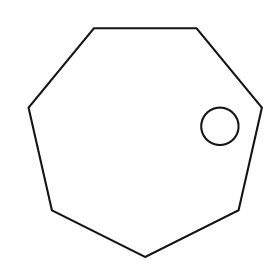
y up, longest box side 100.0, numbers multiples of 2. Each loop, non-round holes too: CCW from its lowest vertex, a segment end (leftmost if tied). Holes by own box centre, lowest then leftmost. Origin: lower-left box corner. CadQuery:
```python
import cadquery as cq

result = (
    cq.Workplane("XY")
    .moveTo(50.0, 0.0)
    .lineTo(90.0, 20.0)
    .lineTo(100.0, 64.0)
    .lineTo(72.0, 98.0)
    .lineTo(28.0, 98.0)
    .lineTo(0.0, 64.0)
    .lineTo(10.0, 20.0)
    .close()
    .moveTo(82.0, 56.0)
    .circle(8.0)
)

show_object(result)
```